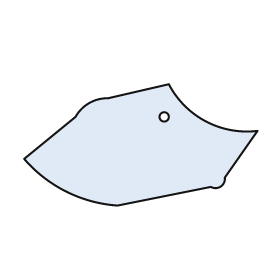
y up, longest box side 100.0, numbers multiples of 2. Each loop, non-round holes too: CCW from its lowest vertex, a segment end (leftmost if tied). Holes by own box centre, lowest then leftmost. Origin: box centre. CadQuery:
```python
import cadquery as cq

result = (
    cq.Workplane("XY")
    .moveTo(-10.0, -26.0)
    .lineTo(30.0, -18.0)
    .threePointArc((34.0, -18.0), (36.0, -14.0))
    .lineTo(50.0, 6.0)
    .threePointArc((28.0, 10.0), (12.0, 26.0))
    .lineTo(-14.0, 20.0)
    .threePointArc((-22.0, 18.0), (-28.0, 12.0))
    .lineTo(-50.0, -6.0)
    .threePointArc((-32.0, -20.0), (-10.0, -26.0))
    .close()
    .moveTo(10.0, 12.0)
    .circle(2.0)
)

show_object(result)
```